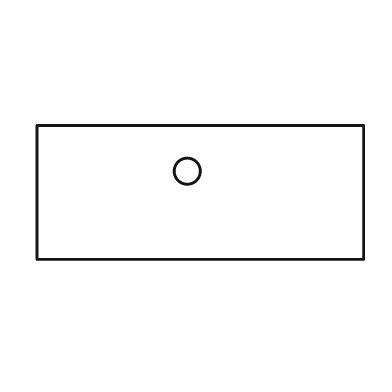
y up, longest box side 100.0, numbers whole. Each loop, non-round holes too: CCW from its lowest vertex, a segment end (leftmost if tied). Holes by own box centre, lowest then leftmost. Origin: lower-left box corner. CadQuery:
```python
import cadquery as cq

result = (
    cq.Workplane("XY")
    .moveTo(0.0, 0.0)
    .lineTo(100.0, 0.0)
    .lineTo(100.0, 41.0)
    .lineTo(0.0, 41.0)
    .close()
    .moveTo(46.0, 27.0)
    .circle(4.0)
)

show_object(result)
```